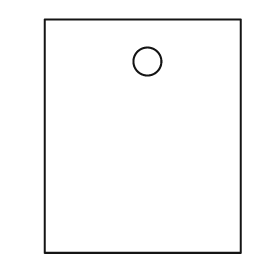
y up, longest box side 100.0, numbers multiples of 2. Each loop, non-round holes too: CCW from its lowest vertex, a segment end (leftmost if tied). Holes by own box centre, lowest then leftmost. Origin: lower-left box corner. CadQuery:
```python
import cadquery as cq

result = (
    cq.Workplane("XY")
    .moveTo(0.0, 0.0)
    .lineTo(84.0, 0.0)
    .lineTo(84.0, 100.0)
    .lineTo(0.0, 100.0)
    .close()
    .moveTo(44.0, 82.0)
    .circle(6.0)
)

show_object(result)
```